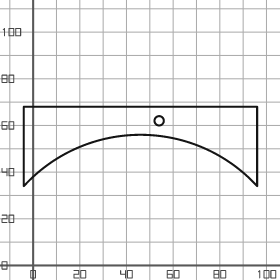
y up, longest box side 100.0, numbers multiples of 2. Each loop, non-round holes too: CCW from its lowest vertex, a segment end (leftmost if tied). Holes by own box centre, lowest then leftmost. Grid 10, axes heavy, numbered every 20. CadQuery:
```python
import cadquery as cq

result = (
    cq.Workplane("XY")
    .moveTo(-4.0, 34.0)
    .threePointArc((46.0, 56.0), (96.0, 34.0))
    .lineTo(96.0, 68.0)
    .lineTo(-4.0, 68.0)
    .close()
    .moveTo(54.0, 62.0)
    .circle(2.0)
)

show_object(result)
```